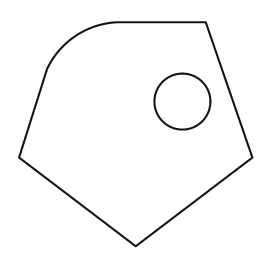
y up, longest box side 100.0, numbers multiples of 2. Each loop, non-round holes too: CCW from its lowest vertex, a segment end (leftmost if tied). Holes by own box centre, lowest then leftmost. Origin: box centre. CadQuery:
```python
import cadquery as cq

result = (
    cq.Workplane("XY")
    .moveTo(0.0, -48.0)
    .lineTo(50.0, -10.0)
    .lineTo(30.0, 48.0)
    .lineTo(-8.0, 48.0)
    .threePointArc((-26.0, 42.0), (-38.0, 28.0))
    .lineTo(-50.0, -10.0)
    .close()
    .moveTo(20.0, 14.0)
    .circle(12.0)
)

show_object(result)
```